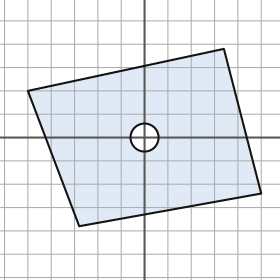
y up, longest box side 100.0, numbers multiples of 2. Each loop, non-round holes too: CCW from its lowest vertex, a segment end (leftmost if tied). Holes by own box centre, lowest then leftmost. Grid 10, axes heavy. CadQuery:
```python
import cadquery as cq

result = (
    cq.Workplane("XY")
    .moveTo(-28.0, -38.0)
    .lineTo(50.0, -24.0)
    .lineTo(34.0, 38.0)
    .lineTo(-50.0, 20.0)
    .close()
    .moveTo(0.0, 0.0)
    .circle(6.0)
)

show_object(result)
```